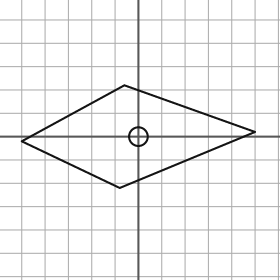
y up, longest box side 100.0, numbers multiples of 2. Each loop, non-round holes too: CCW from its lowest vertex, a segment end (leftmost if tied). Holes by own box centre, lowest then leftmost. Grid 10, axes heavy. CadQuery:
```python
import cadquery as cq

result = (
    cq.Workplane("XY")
    .moveTo(-8.0, -22.0)
    .lineTo(50.0, 2.0)
    .lineTo(-6.0, 22.0)
    .lineTo(-50.0, -2.0)
    .close()
    .moveTo(0.0, 0.0)
    .circle(4.0)
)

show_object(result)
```